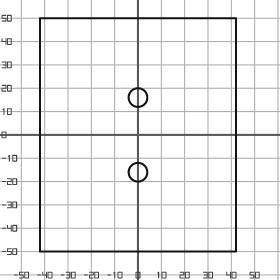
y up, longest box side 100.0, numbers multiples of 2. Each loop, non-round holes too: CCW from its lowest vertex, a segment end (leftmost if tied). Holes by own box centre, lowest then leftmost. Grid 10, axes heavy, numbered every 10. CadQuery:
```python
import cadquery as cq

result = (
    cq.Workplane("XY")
    .moveTo(-42.0, -50.0)
    .lineTo(42.0, -50.0)
    .lineTo(42.0, 50.0)
    .lineTo(-42.0, 50.0)
    .close()
    .moveTo(0.0, -16.0)
    .circle(4.0)
    .moveTo(0.0, 16.0)
    .circle(4.0)
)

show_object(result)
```